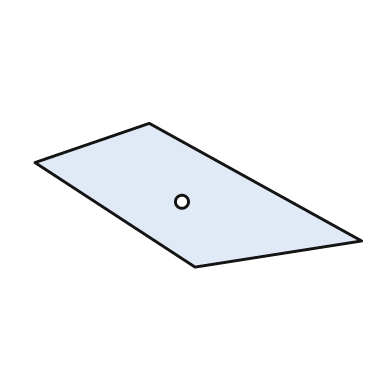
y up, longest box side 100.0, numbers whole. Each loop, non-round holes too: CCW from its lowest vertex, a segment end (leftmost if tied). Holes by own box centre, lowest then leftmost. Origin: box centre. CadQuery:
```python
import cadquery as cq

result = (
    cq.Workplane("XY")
    .moveTo(-1.0, -22.0)
    .lineTo(50.0, -14.0)
    .lineTo(-15.0, 22.0)
    .lineTo(-50.0, 10.0)
    .close()
    .moveTo(-5.0, -2.0)
    .circle(2.0)
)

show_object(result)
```